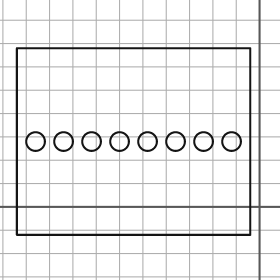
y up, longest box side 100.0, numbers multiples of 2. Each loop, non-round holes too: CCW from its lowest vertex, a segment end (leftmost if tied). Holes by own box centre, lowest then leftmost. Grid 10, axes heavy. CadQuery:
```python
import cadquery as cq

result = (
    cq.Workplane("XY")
    .moveTo(-104.0, -12.0)
    .lineTo(-4.0, -12.0)
    .lineTo(-4.0, 68.0)
    .lineTo(-104.0, 68.0)
    .close()
    .moveTo(-96.0, 28.0)
    .circle(4.0)
    .moveTo(-84.0, 28.0)
    .circle(4.0)
    .moveTo(-72.0, 28.0)
    .circle(4.0)
    .moveTo(-60.0, 28.0)
    .circle(4.0)
    .moveTo(-48.0, 28.0)
    .circle(4.0)
    .moveTo(-36.0, 28.0)
    .circle(4.0)
    .moveTo(-24.0, 28.0)
    .circle(4.0)
    .moveTo(-12.0, 28.0)
    .circle(4.0)
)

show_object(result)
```